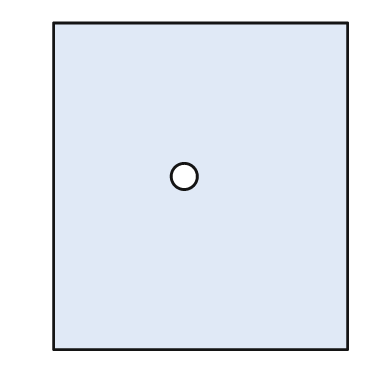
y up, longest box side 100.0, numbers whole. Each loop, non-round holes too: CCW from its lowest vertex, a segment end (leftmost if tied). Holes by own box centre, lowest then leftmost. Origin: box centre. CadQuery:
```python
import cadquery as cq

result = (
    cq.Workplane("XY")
    .moveTo(-45.0, -50.0)
    .lineTo(45.0, -50.0)
    .lineTo(45.0, 50.0)
    .lineTo(-45.0, 50.0)
    .close()
    .moveTo(-5.0, 3.0)
    .circle(4.0)
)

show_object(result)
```